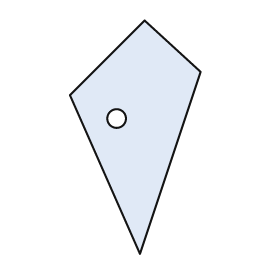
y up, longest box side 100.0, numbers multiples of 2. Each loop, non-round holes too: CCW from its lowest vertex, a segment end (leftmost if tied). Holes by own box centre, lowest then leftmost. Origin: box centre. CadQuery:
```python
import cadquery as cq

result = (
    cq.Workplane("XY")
    .moveTo(2.0, -50.0)
    .lineTo(28.0, 28.0)
    .lineTo(4.0, 50.0)
    .lineTo(-28.0, 18.0)
    .close()
    .moveTo(-8.0, 8.0)
    .circle(4.0)
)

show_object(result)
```